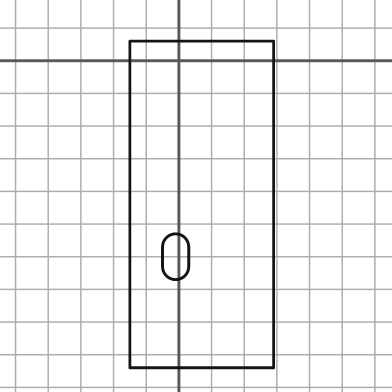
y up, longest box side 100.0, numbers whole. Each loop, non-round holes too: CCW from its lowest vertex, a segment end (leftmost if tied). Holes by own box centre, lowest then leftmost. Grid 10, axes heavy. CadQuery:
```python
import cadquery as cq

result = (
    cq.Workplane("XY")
    .moveTo(-15.0, -94.0)
    .lineTo(29.0, -94.0)
    .lineTo(29.0, 6.0)
    .lineTo(-15.0, 6.0)
    .close()
    .moveTo(-5.0, -63.0)
    .threePointArc((-1.0, -67.0), (3.0, -63.0))
    .lineTo(3.0, -57.0)
    .threePointArc((-1.0, -53.0), (-5.0, -57.0))
    .close()
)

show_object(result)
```